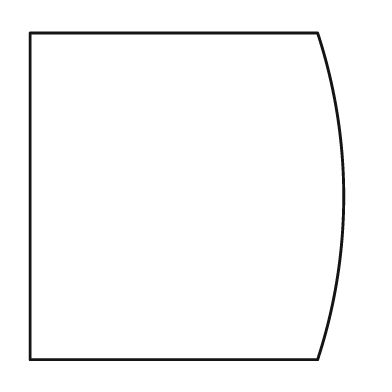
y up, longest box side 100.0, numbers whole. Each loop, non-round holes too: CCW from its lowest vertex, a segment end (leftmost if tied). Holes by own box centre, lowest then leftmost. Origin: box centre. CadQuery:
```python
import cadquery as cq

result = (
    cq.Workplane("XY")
    .moveTo(-48.0, -50.0)
    .lineTo(40.0, -50.0)
    .threePointArc((48.0, 0.0), (40.0, 50.0))
    .lineTo(-48.0, 50.0)
    .close()
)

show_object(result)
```